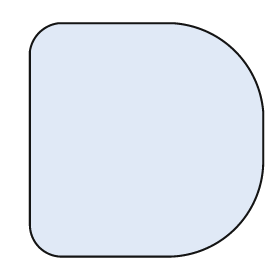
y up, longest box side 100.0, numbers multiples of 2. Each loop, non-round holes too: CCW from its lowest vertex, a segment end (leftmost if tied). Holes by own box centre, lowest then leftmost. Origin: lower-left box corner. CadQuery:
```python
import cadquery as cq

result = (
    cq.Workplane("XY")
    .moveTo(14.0, 0.0)
    .lineTo(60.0, 0.0)
    .threePointArc((88.0, 12.0), (100.0, 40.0))
    .lineTo(100.0, 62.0)
    .threePointArc((88.0, 88.0), (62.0, 100.0))
    .lineTo(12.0, 100.0)
    .threePointArc((4.0, 96.0), (0.0, 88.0))
    .lineTo(0.0, 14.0)
    .threePointArc((4.0, 4.0), (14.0, 0.0))
    .close()
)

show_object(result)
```